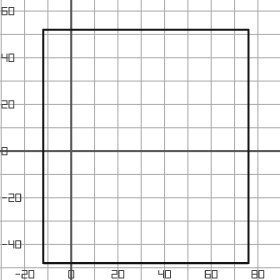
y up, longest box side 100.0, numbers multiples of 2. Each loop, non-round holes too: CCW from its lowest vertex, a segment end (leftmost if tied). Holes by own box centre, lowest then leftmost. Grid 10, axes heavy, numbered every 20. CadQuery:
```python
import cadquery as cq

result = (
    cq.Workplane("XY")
    .moveTo(-12.0, -48.0)
    .lineTo(76.0, -48.0)
    .lineTo(76.0, 52.0)
    .lineTo(-12.0, 52.0)
    .close()
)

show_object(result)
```